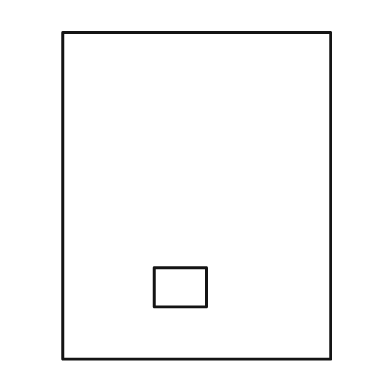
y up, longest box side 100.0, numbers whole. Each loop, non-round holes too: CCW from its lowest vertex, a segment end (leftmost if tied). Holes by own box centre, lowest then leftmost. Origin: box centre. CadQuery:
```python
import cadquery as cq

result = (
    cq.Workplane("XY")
    .moveTo(-41.0, -50.0)
    .lineTo(41.0, -50.0)
    .lineTo(41.0, 50.0)
    .lineTo(-41.0, 50.0)
    .close()
    .moveTo(-13.0, -34.0)
    .lineTo(3.0, -34.0)
    .lineTo(3.0, -22.0)
    .lineTo(-13.0, -22.0)
    .close()
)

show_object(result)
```